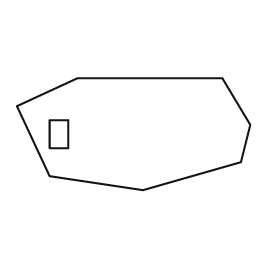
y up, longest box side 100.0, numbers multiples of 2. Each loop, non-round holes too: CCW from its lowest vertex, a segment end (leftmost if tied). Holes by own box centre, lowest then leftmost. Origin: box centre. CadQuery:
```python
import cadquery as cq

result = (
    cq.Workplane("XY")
    .moveTo(4.0, -24.0)
    .lineTo(46.0, -12.0)
    .lineTo(50.0, 4.0)
    .lineTo(38.0, 24.0)
    .lineTo(-24.0, 24.0)
    .lineTo(-50.0, 12.0)
    .lineTo(-36.0, -18.0)
    .close()
    .moveTo(-36.0, -6.0)
    .lineTo(-28.0, -6.0)
    .lineTo(-28.0, 6.0)
    .lineTo(-36.0, 6.0)
    .close()
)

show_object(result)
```